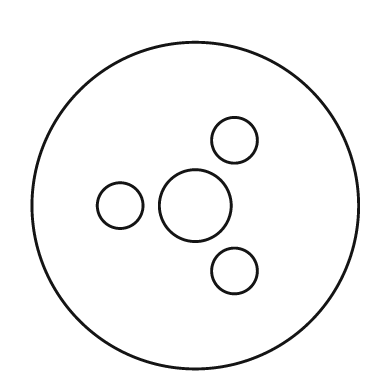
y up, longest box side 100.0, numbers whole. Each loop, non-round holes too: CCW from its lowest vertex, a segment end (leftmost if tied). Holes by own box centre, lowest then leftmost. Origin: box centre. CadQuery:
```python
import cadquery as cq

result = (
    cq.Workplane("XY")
    .moveTo(0.0, 0.0)
    .circle(50.0)
    .moveTo(12.0, -20.0)
    .circle(7.0)
    .moveTo(-23.0, 0.0)
    .circle(7.0)
    .moveTo(0.0, 0.0)
    .circle(11.0)
    .moveTo(12.0, 20.0)
    .circle(7.0)
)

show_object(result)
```